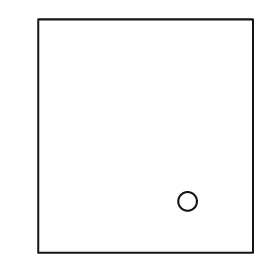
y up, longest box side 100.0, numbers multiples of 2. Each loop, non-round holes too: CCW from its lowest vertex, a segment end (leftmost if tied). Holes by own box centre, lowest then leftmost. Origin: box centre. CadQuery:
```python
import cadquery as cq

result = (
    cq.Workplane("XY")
    .moveTo(-46.0, -50.0)
    .lineTo(46.0, -50.0)
    .lineTo(46.0, 50.0)
    .lineTo(-46.0, 50.0)
    .close()
    .moveTo(18.0, -28.0)
    .circle(4.0)
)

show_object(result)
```